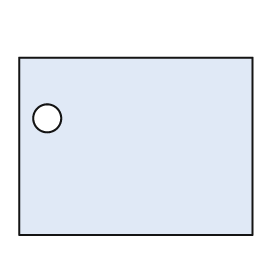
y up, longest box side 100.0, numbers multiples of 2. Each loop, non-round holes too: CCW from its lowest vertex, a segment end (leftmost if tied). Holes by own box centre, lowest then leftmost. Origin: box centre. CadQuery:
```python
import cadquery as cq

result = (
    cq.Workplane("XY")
    .moveTo(-50.0, -38.0)
    .lineTo(50.0, -38.0)
    .lineTo(50.0, 38.0)
    .lineTo(-50.0, 38.0)
    .close()
    .moveTo(-38.0, 12.0)
    .circle(6.0)
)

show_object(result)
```